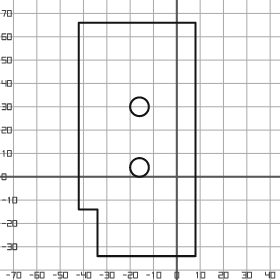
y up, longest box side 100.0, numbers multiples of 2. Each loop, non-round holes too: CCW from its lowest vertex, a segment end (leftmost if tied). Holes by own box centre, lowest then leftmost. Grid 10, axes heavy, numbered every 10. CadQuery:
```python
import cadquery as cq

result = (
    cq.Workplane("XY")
    .moveTo(-34.0, -34.0)
    .lineTo(8.0, -34.0)
    .lineTo(8.0, 66.0)
    .lineTo(-42.0, 66.0)
    .lineTo(-42.0, -14.0)
    .lineTo(-34.0, -14.0)
    .close()
    .moveTo(-16.0, 4.0)
    .circle(4.0)
    .moveTo(-16.0, 30.0)
    .circle(4.0)
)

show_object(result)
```